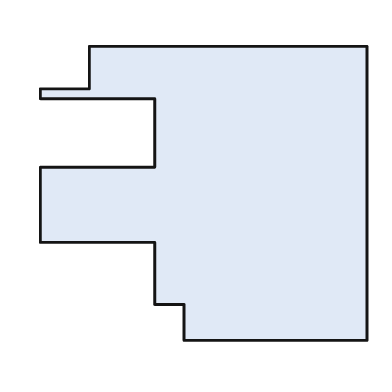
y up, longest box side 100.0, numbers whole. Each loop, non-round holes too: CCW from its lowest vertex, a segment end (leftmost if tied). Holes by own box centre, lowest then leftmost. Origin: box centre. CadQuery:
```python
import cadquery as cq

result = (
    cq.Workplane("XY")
    .moveTo(-6.0, -45.0)
    .lineTo(50.0, -45.0)
    .lineTo(50.0, 45.0)
    .lineTo(-35.0, 45.0)
    .lineTo(-35.0, 32.0)
    .lineTo(-50.0, 32.0)
    .lineTo(-50.0, 29.0)
    .lineTo(-15.0, 29.0)
    .lineTo(-15.0, 8.0)
    .lineTo(-50.0, 8.0)
    .lineTo(-50.0, -15.0)
    .lineTo(-15.0, -15.0)
    .lineTo(-15.0, -34.0)
    .lineTo(-6.0, -34.0)
    .close()
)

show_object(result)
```